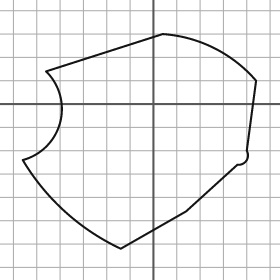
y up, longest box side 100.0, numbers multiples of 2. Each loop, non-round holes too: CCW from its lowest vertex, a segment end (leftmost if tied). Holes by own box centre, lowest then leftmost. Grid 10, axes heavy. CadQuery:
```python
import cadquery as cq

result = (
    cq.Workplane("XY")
    .moveTo(-14.0, -62.0)
    .lineTo(14.0, -46.0)
    .lineTo(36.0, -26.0)
    .threePointArc((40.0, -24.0), (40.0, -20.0))
    .lineTo(44.0, 10.0)
    .threePointArc((26.0, 24.0), (4.0, 30.0))
    .lineTo(-46.0, 14.0)
    .threePointArc((-40.0, -8.0), (-56.0, -24.0))
    .threePointArc((-38.0, -46.0), (-14.0, -62.0))
    .close()
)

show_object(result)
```